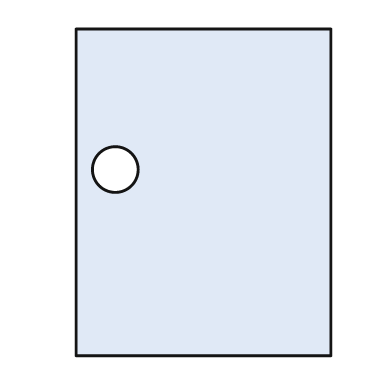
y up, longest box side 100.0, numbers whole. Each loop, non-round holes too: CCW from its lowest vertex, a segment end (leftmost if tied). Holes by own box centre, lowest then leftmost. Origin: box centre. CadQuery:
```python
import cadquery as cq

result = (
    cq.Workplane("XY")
    .moveTo(-39.0, -50.0)
    .lineTo(39.0, -50.0)
    .lineTo(39.0, 50.0)
    .lineTo(-39.0, 50.0)
    .close()
    .moveTo(-27.0, 7.0)
    .circle(7.0)
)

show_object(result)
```